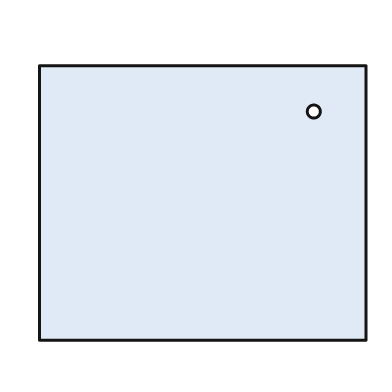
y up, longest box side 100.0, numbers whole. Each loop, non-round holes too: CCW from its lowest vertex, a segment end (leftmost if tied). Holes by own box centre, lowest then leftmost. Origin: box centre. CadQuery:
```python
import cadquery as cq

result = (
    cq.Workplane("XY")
    .moveTo(-50.0, -42.0)
    .lineTo(50.0, -42.0)
    .lineTo(50.0, 42.0)
    .lineTo(-50.0, 42.0)
    .close()
    .moveTo(34.0, 28.0)
    .circle(2.0)
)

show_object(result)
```